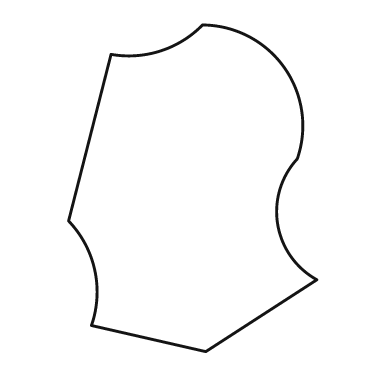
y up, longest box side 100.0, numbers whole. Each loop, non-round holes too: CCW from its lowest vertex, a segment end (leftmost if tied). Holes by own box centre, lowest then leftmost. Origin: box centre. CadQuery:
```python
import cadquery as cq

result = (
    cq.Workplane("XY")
    .moveTo(4.0, -50.0)
    .lineTo(38.0, -28.0)
    .threePointArc((26.0, -11.0), (32.0, 9.0))
    .threePointArc((28.0, 37.0), (3.0, 50.0))
    .threePointArc((-10.0, 42.0), (-25.0, 41.0))
    .lineTo(-38.0, -10.0)
    .threePointArc((-30.0, -25.0), (-31.0, -42.0))
    .close()
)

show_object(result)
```